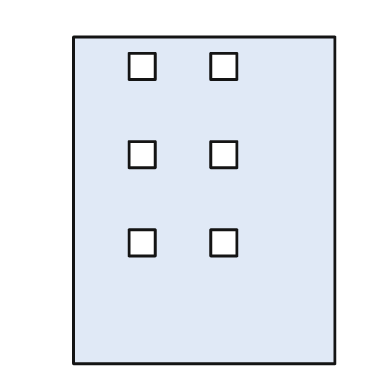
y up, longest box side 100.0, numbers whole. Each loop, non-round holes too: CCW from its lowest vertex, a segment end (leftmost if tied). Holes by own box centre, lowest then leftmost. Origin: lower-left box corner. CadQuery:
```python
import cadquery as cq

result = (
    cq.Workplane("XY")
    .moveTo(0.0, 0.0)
    .lineTo(80.0, 0.0)
    .lineTo(80.0, 100.0)
    .lineTo(0.0, 100.0)
    .close()
    .moveTo(17.0, 33.0)
    .lineTo(25.0, 33.0)
    .lineTo(25.0, 41.0)
    .lineTo(17.0, 41.0)
    .close()
    .moveTo(42.0, 33.0)
    .lineTo(50.0, 33.0)
    .lineTo(50.0, 41.0)
    .lineTo(42.0, 41.0)
    .close()
    .moveTo(17.0, 60.0)
    .lineTo(25.0, 60.0)
    .lineTo(25.0, 68.0)
    .lineTo(17.0, 68.0)
    .close()
    .moveTo(42.0, 60.0)
    .lineTo(50.0, 60.0)
    .lineTo(50.0, 68.0)
    .lineTo(42.0, 68.0)
    .close()
    .moveTo(17.0, 87.0)
    .lineTo(25.0, 87.0)
    .lineTo(25.0, 95.0)
    .lineTo(17.0, 95.0)
    .close()
    .moveTo(42.0, 87.0)
    .lineTo(50.0, 87.0)
    .lineTo(50.0, 95.0)
    .lineTo(42.0, 95.0)
    .close()
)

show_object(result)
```